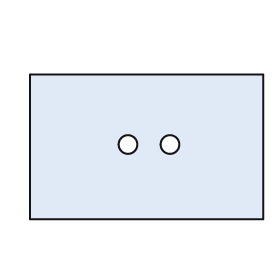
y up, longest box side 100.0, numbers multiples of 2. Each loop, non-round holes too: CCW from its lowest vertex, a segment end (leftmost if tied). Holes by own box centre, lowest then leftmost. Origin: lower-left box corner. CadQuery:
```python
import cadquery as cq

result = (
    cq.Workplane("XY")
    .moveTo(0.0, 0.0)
    .lineTo(100.0, 0.0)
    .lineTo(100.0, 62.0)
    .lineTo(0.0, 62.0)
    .close()
    .moveTo(42.0, 32.0)
    .circle(4.0)
    .moveTo(60.0, 32.0)
    .circle(4.0)
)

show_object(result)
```